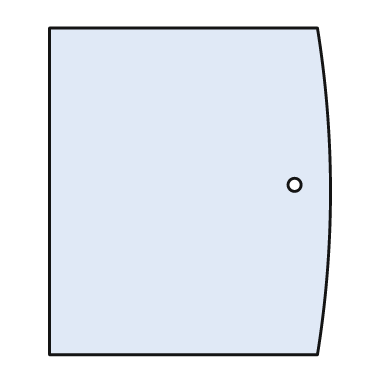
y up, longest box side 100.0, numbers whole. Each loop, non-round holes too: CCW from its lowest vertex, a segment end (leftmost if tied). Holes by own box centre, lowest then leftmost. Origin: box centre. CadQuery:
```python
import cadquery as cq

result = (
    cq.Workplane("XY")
    .moveTo(-43.0, -50.0)
    .lineTo(39.0, -50.0)
    .threePointArc((43.0, 0.0), (39.0, 50.0))
    .lineTo(-43.0, 50.0)
    .close()
    .moveTo(32.0, 2.0)
    .circle(2.0)
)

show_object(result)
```